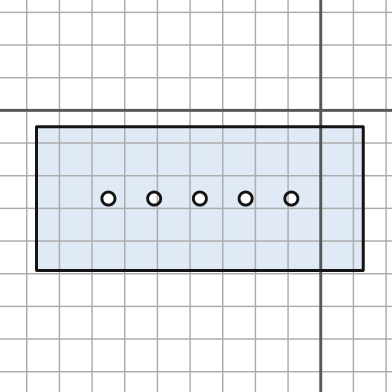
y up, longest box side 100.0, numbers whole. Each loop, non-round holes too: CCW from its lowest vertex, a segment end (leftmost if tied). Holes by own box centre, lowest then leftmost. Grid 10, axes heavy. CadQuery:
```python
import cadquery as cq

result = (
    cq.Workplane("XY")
    .moveTo(-87.0, -49.0)
    .lineTo(13.0, -49.0)
    .lineTo(13.0, -5.0)
    .lineTo(-87.0, -5.0)
    .close()
    .moveTo(-65.0, -27.0)
    .circle(2.0)
    .moveTo(-51.0, -27.0)
    .circle(2.0)
    .moveTo(-37.0, -27.0)
    .circle(2.0)
    .moveTo(-23.0, -27.0)
    .circle(2.0)
    .moveTo(-9.0, -27.0)
    .circle(2.0)
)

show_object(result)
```